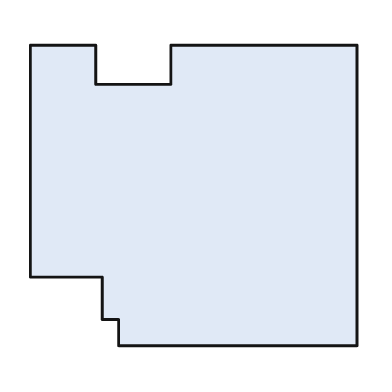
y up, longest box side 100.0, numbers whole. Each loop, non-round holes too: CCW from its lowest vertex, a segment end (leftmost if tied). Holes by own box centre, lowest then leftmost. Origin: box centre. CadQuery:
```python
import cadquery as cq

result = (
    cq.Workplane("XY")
    .moveTo(-23.0, -46.0)
    .lineTo(50.0, -46.0)
    .lineTo(50.0, 46.0)
    .lineTo(-7.0, 46.0)
    .lineTo(-7.0, 34.0)
    .lineTo(-30.0, 34.0)
    .lineTo(-30.0, 46.0)
    .lineTo(-50.0, 46.0)
    .lineTo(-50.0, -25.0)
    .lineTo(-28.0, -25.0)
    .lineTo(-28.0, -38.0)
    .lineTo(-23.0, -38.0)
    .close()
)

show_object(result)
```